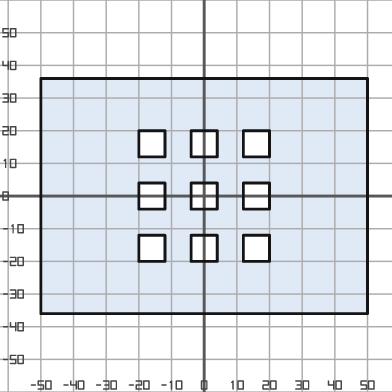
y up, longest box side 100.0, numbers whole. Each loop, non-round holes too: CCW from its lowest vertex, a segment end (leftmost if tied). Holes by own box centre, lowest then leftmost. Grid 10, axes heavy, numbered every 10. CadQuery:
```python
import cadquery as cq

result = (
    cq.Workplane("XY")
    .moveTo(-50.0, -36.0)
    .lineTo(50.0, -36.0)
    .lineTo(50.0, 36.0)
    .lineTo(-50.0, 36.0)
    .close()
    .moveTo(-20.0, -20.0)
    .lineTo(-12.0, -20.0)
    .lineTo(-12.0, -12.0)
    .lineTo(-20.0, -12.0)
    .close()
    .moveTo(-4.0, -20.0)
    .lineTo(4.0, -20.0)
    .lineTo(4.0, -12.0)
    .lineTo(-4.0, -12.0)
    .close()
    .moveTo(12.0, -20.0)
    .lineTo(20.0, -20.0)
    .lineTo(20.0, -12.0)
    .lineTo(12.0, -12.0)
    .close()
    .moveTo(-20.0, -4.0)
    .lineTo(-12.0, -4.0)
    .lineTo(-12.0, 4.0)
    .lineTo(-20.0, 4.0)
    .close()
    .moveTo(-4.0, -4.0)
    .lineTo(4.0, -4.0)
    .lineTo(4.0, 4.0)
    .lineTo(-4.0, 4.0)
    .close()
    .moveTo(12.0, -4.0)
    .lineTo(20.0, -4.0)
    .lineTo(20.0, 4.0)
    .lineTo(12.0, 4.0)
    .close()
    .moveTo(-20.0, 12.0)
    .lineTo(-12.0, 12.0)
    .lineTo(-12.0, 20.0)
    .lineTo(-20.0, 20.0)
    .close()
    .moveTo(-4.0, 12.0)
    .lineTo(4.0, 12.0)
    .lineTo(4.0, 20.0)
    .lineTo(-4.0, 20.0)
    .close()
    .moveTo(12.0, 12.0)
    .lineTo(20.0, 12.0)
    .lineTo(20.0, 20.0)
    .lineTo(12.0, 20.0)
    .close()
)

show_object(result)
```